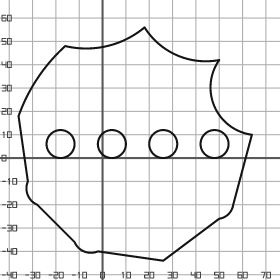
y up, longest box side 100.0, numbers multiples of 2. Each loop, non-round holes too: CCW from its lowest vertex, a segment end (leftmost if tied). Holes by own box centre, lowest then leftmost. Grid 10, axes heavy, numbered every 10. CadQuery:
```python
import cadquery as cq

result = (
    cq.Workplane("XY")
    .moveTo(26.0, -44.0)
    .lineTo(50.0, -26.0)
    .threePointArc((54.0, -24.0), (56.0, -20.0))
    .lineTo(64.0, 10.0)
    .threePointArc((48.0, 22.0), (50.0, 42.0))
    .threePointArc((32.0, 44.0), (18.0, 56.0))
    .threePointArc((2.0, 48.0), (-16.0, 48.0))
    .threePointArc((-28.0, 34.0), (-36.0, 18.0))
    .lineTo(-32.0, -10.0)
    .threePointArc((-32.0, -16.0), (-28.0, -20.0))
    .lineTo(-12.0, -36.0)
    .threePointArc((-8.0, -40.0), (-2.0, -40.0))
    .close()
    .moveTo(-18.0, 6.0)
    .circle(6.0)
    .moveTo(4.0, 6.0)
    .circle(6.0)
    .moveTo(26.0, 6.0)
    .circle(6.0)
    .moveTo(48.0, 6.0)
    .circle(6.0)
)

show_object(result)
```